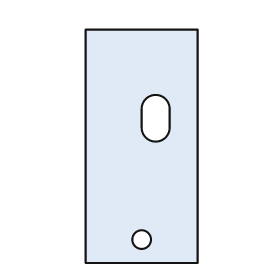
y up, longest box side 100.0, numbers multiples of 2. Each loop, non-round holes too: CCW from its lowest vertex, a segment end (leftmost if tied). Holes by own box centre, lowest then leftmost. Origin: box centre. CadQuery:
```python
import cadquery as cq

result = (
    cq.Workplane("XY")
    .moveTo(-24.0, -50.0)
    .lineTo(24.0, -50.0)
    .lineTo(24.0, 50.0)
    .lineTo(-24.0, 50.0)
    .close()
    .moveTo(0.0, -40.0)
    .circle(4.0)
    .moveTo(0.0, 8.0)
    .threePointArc((6.0, 2.0), (12.0, 8.0))
    .lineTo(12.0, 16.0)
    .threePointArc((6.0, 22.0), (0.0, 16.0))
    .close()
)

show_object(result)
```